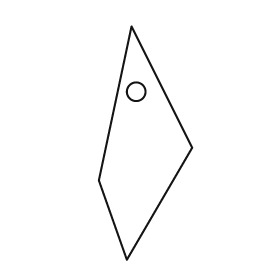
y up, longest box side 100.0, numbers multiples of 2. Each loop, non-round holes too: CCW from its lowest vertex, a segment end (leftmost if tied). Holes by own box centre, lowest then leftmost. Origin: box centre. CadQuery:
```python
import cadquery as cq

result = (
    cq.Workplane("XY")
    .moveTo(-8.0, -50.0)
    .lineTo(20.0, -2.0)
    .lineTo(-6.0, 50.0)
    .lineTo(-20.0, -16.0)
    .close()
    .moveTo(-4.0, 22.0)
    .circle(4.0)
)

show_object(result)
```